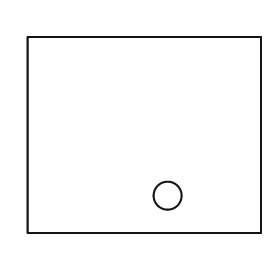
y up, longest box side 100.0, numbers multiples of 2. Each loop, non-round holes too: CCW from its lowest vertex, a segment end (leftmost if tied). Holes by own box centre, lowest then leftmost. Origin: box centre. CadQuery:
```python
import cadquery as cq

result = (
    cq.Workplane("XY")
    .moveTo(-50.0, -42.0)
    .lineTo(50.0, -42.0)
    .lineTo(50.0, 42.0)
    .lineTo(-50.0, 42.0)
    .close()
    .moveTo(10.0, -26.0)
    .circle(6.0)
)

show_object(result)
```